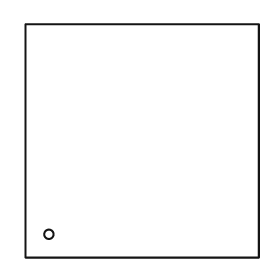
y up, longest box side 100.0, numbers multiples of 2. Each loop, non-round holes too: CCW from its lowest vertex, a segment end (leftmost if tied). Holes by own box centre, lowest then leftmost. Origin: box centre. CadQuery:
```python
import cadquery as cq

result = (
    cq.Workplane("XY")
    .moveTo(-50.0, -50.0)
    .lineTo(50.0, -50.0)
    .lineTo(50.0, 50.0)
    .lineTo(-50.0, 50.0)
    .close()
    .moveTo(-40.0, -40.0)
    .circle(2.0)
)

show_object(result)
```